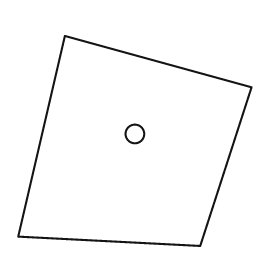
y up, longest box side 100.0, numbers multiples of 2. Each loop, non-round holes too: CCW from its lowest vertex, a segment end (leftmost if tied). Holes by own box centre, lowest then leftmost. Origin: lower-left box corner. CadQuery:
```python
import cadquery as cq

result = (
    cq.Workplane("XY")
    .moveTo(78.0, 0.0)
    .lineTo(100.0, 68.0)
    .lineTo(20.0, 90.0)
    .lineTo(0.0, 4.0)
    .close()
    .moveTo(50.0, 48.0)
    .circle(4.0)
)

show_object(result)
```